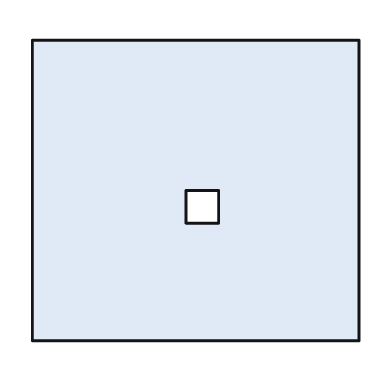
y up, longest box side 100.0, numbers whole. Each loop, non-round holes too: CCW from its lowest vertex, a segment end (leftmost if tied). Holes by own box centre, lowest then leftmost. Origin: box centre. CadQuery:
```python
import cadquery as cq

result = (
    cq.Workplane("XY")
    .moveTo(-50.0, -46.0)
    .lineTo(50.0, -46.0)
    .lineTo(50.0, 46.0)
    .lineTo(-50.0, 46.0)
    .close()
    .moveTo(-3.0, -10.0)
    .lineTo(7.0, -10.0)
    .lineTo(7.0, 0.0)
    .lineTo(-3.0, 0.0)
    .close()
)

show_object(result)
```